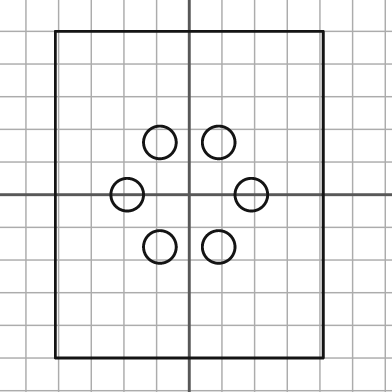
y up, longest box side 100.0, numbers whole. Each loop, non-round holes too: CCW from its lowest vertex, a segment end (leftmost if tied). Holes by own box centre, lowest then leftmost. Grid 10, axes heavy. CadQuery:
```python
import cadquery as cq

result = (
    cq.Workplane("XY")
    .moveTo(-41.0, -50.0)
    .lineTo(41.0, -50.0)
    .lineTo(41.0, 50.0)
    .lineTo(-41.0, 50.0)
    .close()
    .moveTo(-9.0, -16.0)
    .circle(5.0)
    .moveTo(9.0, -16.0)
    .circle(5.0)
    .moveTo(-19.0, 0.0)
    .circle(5.0)
    .moveTo(19.0, 0.0)
    .circle(5.0)
    .moveTo(-9.0, 16.0)
    .circle(5.0)
    .moveTo(9.0, 16.0)
    .circle(5.0)
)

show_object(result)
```